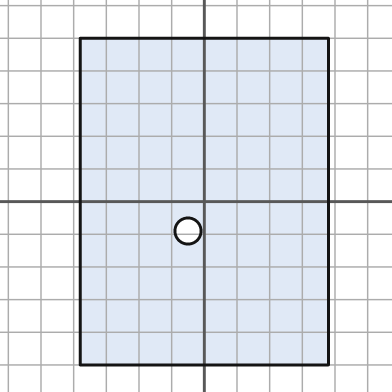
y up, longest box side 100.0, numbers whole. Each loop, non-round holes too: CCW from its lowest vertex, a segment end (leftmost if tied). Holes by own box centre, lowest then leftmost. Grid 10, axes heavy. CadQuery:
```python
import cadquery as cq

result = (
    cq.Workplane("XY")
    .moveTo(-38.0, -50.0)
    .lineTo(38.0, -50.0)
    .lineTo(38.0, 50.0)
    .lineTo(-38.0, 50.0)
    .close()
    .moveTo(-5.0, -9.0)
    .circle(4.0)
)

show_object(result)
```